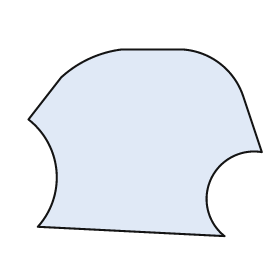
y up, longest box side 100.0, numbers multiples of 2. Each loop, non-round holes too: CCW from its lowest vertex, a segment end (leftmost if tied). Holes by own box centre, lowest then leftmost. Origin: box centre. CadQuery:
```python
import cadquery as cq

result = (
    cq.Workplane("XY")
    .moveTo(34.0, -40.0)
    .threePointArc((28.0, -16.0), (50.0, -4.0))
    .lineTo(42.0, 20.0)
    .threePointArc((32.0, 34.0), (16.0, 40.0))
    .lineTo(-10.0, 40.0)
    .threePointArc((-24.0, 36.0), (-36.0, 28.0))
    .lineTo(-50.0, 10.0)
    .threePointArc((-38.0, -12.0), (-46.0, -36.0))
    .close()
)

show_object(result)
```